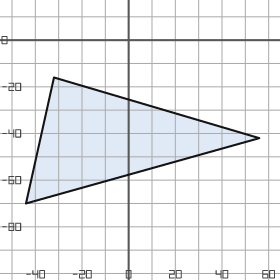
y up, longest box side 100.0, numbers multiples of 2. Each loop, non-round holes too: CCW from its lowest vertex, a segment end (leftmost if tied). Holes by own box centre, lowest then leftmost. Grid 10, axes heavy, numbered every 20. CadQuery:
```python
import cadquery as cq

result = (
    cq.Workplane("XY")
    .moveTo(-44.0, -70.0)
    .lineTo(56.0, -42.0)
    .lineTo(-32.0, -16.0)
    .close()
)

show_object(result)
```